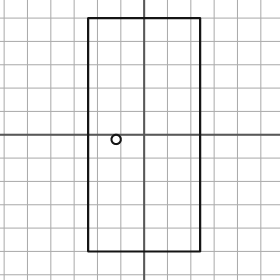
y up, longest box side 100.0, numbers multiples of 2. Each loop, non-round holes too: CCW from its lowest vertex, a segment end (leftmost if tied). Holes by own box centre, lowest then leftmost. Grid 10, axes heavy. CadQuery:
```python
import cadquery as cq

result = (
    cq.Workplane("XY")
    .moveTo(-24.0, -50.0)
    .lineTo(24.0, -50.0)
    .lineTo(24.0, 50.0)
    .lineTo(-24.0, 50.0)
    .close()
    .moveTo(-12.0, -2.0)
    .circle(2.0)
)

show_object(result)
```